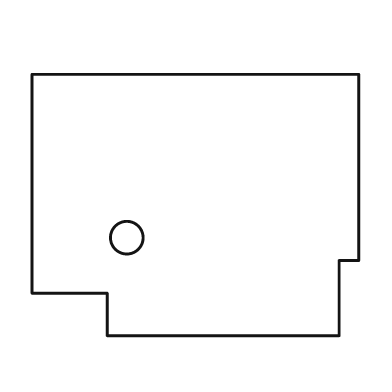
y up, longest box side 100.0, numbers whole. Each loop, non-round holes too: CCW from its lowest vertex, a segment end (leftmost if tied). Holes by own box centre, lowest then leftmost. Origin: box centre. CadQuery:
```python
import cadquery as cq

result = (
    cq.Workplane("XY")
    .moveTo(-27.0, -40.0)
    .lineTo(44.0, -40.0)
    .lineTo(44.0, -17.0)
    .lineTo(50.0, -17.0)
    .lineTo(50.0, 40.0)
    .lineTo(-50.0, 40.0)
    .lineTo(-50.0, -27.0)
    .lineTo(-27.0, -27.0)
    .close()
    .moveTo(-21.0, -10.0)
    .circle(5.0)
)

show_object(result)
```